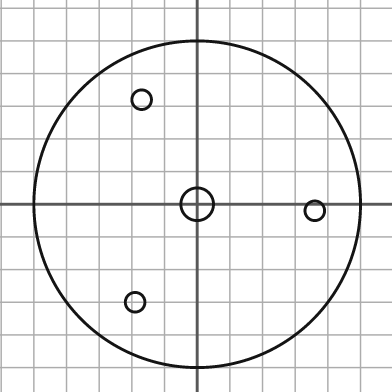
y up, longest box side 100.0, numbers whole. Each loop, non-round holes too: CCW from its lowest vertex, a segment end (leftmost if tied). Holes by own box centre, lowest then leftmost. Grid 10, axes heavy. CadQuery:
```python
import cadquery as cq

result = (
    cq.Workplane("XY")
    .moveTo(0.0, 0.0)
    .circle(50.0)
    .moveTo(-19.0, -30.0)
    .circle(3.0)
    .moveTo(36.0, -2.0)
    .circle(3.0)
    .moveTo(0.0, 0.0)
    .circle(5.0)
    .moveTo(-17.0, 32.0)
    .circle(3.0)
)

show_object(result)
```